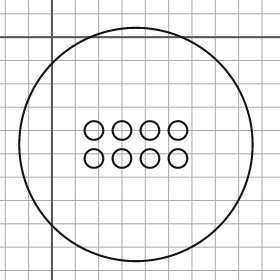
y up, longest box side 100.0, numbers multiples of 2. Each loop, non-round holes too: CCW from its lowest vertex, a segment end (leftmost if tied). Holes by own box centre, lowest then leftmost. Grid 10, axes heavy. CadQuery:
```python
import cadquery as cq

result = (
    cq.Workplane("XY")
    .moveTo(36.0, -46.0)
    .circle(50.0)
    .moveTo(18.0, -52.0)
    .circle(4.0)
    .moveTo(30.0, -52.0)
    .circle(4.0)
    .moveTo(42.0, -52.0)
    .circle(4.0)
    .moveTo(54.0, -52.0)
    .circle(4.0)
    .moveTo(18.0, -40.0)
    .circle(4.0)
    .moveTo(30.0, -40.0)
    .circle(4.0)
    .moveTo(42.0, -40.0)
    .circle(4.0)
    .moveTo(54.0, -40.0)
    .circle(4.0)
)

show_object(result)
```